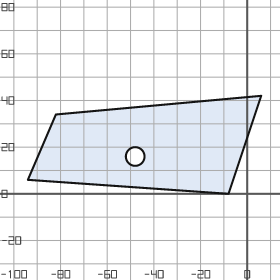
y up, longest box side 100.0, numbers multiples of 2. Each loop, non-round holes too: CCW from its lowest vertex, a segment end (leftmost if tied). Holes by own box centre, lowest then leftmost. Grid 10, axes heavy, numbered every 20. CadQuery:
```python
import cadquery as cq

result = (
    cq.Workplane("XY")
    .moveTo(-8.0, 0.0)
    .lineTo(6.0, 42.0)
    .lineTo(-82.0, 34.0)
    .lineTo(-94.0, 6.0)
    .close()
    .moveTo(-48.0, 16.0)
    .circle(4.0)
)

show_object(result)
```